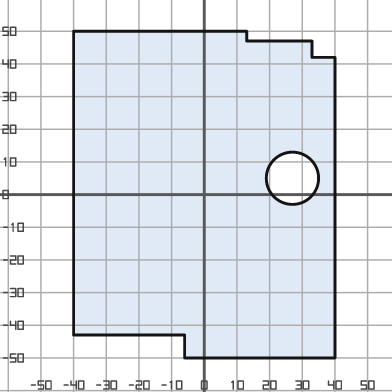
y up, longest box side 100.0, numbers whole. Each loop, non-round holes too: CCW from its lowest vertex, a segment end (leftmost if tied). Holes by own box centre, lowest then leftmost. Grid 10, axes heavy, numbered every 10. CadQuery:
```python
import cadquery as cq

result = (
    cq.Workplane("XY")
    .moveTo(-6.0, -50.0)
    .lineTo(40.0, -50.0)
    .lineTo(40.0, 42.0)
    .lineTo(33.0, 42.0)
    .lineTo(33.0, 47.0)
    .lineTo(13.0, 47.0)
    .lineTo(13.0, 50.0)
    .lineTo(-40.0, 50.0)
    .lineTo(-40.0, -43.0)
    .lineTo(-6.0, -43.0)
    .close()
    .moveTo(27.0, 5.0)
    .circle(8.0)
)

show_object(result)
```